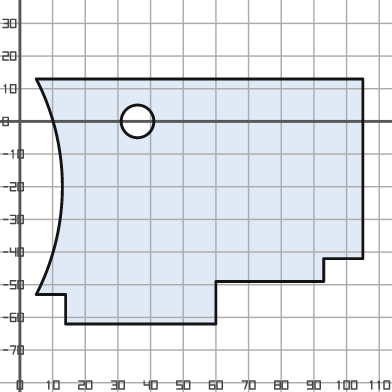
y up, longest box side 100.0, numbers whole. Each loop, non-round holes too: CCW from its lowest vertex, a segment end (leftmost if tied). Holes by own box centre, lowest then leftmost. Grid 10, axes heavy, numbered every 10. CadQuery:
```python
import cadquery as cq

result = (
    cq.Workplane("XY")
    .moveTo(14.0, -62.0)
    .lineTo(60.0, -62.0)
    .lineTo(60.0, -49.0)
    .lineTo(93.0, -49.0)
    .lineTo(93.0, -42.0)
    .lineTo(105.0, -42.0)
    .lineTo(105.0, 13.0)
    .lineTo(5.0, 13.0)
    .threePointArc((13.0, -20.0), (5.0, -53.0))
    .lineTo(14.0, -53.0)
    .close()
    .moveTo(36.0, 0.0)
    .circle(5.0)
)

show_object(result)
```